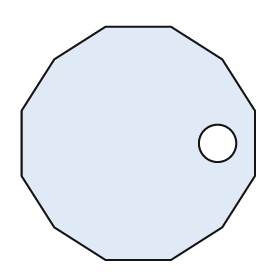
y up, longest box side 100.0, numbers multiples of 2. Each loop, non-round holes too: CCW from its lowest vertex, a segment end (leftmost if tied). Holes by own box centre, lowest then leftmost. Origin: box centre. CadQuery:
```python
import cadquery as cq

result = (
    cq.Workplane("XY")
    .moveTo(-14.0, -50.0)
    .lineTo(14.0, -50.0)
    .lineTo(36.0, -36.0)
    .lineTo(50.0, -14.0)
    .lineTo(50.0, 14.0)
    .lineTo(36.0, 36.0)
    .lineTo(14.0, 50.0)
    .lineTo(-14.0, 50.0)
    .lineTo(-36.0, 36.0)
    .lineTo(-50.0, 14.0)
    .lineTo(-50.0, -14.0)
    .lineTo(-36.0, -36.0)
    .close()
    .moveTo(34.0, 0.0)
    .circle(8.0)
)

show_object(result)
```